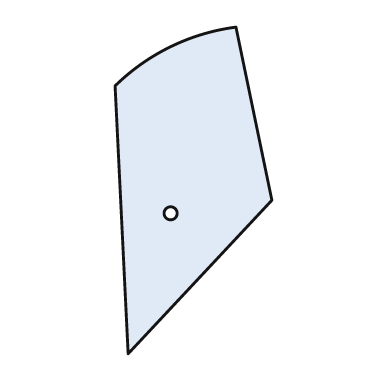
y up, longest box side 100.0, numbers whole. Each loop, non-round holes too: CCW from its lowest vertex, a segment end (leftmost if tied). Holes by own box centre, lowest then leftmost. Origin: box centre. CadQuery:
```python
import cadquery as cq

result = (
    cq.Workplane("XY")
    .moveTo(-20.0, -50.0)
    .lineTo(24.0, -3.0)
    .lineTo(13.0, 50.0)
    .threePointArc((-7.0, 44.0), (-24.0, 32.0))
    .close()
    .moveTo(-7.0, -7.0)
    .circle(2.0)
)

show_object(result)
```